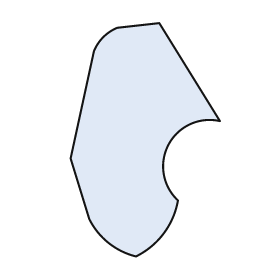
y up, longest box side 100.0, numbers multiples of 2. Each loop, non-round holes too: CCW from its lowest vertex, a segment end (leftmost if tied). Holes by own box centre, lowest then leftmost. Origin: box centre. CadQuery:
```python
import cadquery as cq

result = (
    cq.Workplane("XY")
    .moveTo(-4.0, -50.0)
    .threePointArc((8.0, -40.0), (14.0, -26.0))
    .threePointArc((10.0, -2.0), (32.0, 8.0))
    .lineTo(6.0, 50.0)
    .lineTo(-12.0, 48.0)
    .threePointArc((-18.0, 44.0), (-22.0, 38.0))
    .lineTo(-32.0, -8.0)
    .lineTo(-24.0, -34.0)
    .threePointArc((-16.0, -44.0), (-4.0, -50.0))
    .close()
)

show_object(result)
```